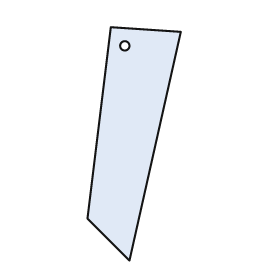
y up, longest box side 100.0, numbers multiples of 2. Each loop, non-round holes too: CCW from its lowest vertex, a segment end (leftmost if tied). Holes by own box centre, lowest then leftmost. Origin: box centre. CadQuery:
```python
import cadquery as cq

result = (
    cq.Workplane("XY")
    .moveTo(-2.0, -50.0)
    .lineTo(20.0, 48.0)
    .lineTo(-10.0, 50.0)
    .lineTo(-20.0, -32.0)
    .close()
    .moveTo(-4.0, 42.0)
    .circle(2.0)
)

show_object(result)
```